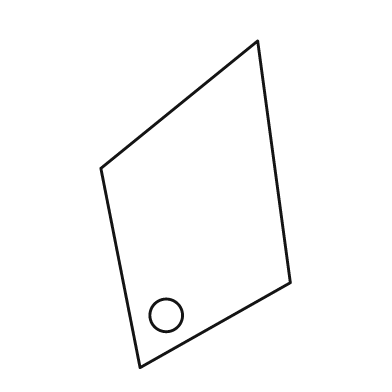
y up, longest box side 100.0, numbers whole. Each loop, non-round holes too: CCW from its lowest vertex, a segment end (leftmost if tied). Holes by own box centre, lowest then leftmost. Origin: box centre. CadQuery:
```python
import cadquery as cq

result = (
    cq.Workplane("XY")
    .moveTo(-17.0, -50.0)
    .lineTo(29.0, -24.0)
    .lineTo(19.0, 50.0)
    .lineTo(-29.0, 11.0)
    .close()
    .moveTo(-9.0, -34.0)
    .circle(5.0)
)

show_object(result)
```